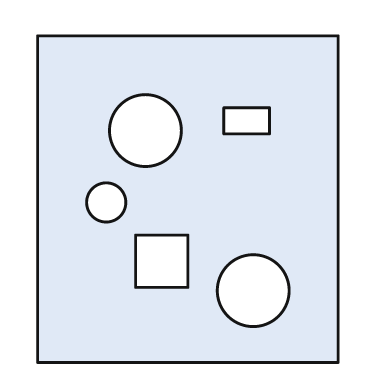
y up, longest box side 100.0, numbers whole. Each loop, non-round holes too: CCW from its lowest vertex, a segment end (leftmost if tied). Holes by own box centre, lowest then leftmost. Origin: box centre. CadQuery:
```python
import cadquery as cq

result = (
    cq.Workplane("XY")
    .moveTo(-46.0, -50.0)
    .lineTo(46.0, -50.0)
    .lineTo(46.0, 50.0)
    .lineTo(-46.0, 50.0)
    .close()
    .moveTo(20.0, -28.0)
    .circle(11.0)
    .moveTo(-16.0, -27.0)
    .lineTo(0.0, -27.0)
    .lineTo(0.0, -11.0)
    .lineTo(-16.0, -11.0)
    .close()
    .moveTo(-25.0, -1.0)
    .circle(6.0)
    .moveTo(-13.0, 21.0)
    .circle(11.0)
    .moveTo(11.0, 20.0)
    .lineTo(25.0, 20.0)
    .lineTo(25.0, 28.0)
    .lineTo(11.0, 28.0)
    .close()
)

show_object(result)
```